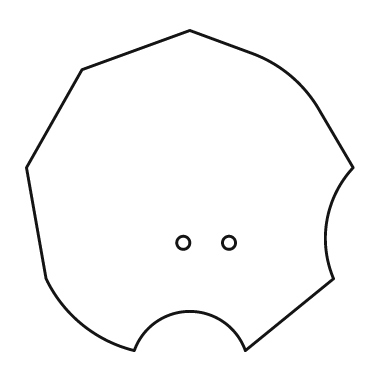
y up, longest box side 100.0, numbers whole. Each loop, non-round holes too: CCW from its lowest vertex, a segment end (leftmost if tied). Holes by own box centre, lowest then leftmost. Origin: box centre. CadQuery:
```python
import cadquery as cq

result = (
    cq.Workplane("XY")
    .moveTo(-17.0, -49.0)
    .threePointArc((0.0, -37.0), (17.0, -49.0))
    .lineTo(44.0, -27.0)
    .threePointArc((42.0, -9.0), (50.0, 7.0))
    .lineTo(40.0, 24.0)
    .threePointArc((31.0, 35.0), (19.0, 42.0))
    .lineTo(0.0, 49.0)
    .lineTo(-33.0, 37.0)
    .lineTo(-50.0, 7.0)
    .lineTo(-44.0, -27.0)
    .threePointArc((-33.0, -41.0), (-17.0, -49.0))
    .close()
    .moveTo(-2.0, -16.0)
    .circle(2.0)
    .moveTo(12.0, -16.0)
    .circle(2.0)
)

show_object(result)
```